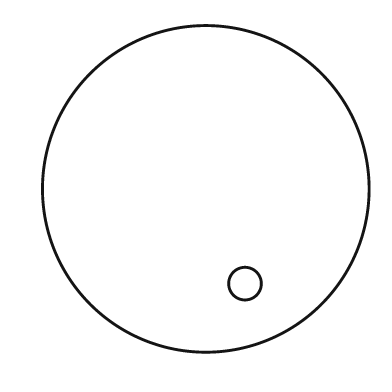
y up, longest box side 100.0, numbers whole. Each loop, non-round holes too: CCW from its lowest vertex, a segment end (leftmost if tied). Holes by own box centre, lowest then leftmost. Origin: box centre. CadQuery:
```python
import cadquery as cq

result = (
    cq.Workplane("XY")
    .moveTo(0.0, 0.0)
    .circle(50.0)
    .moveTo(12.0, -29.0)
    .circle(5.0)
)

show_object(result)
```